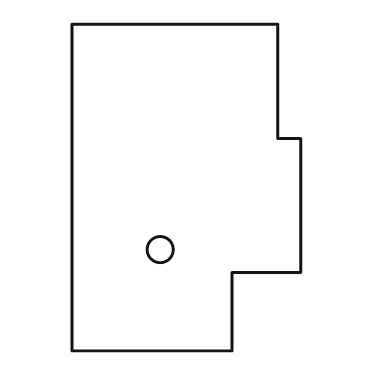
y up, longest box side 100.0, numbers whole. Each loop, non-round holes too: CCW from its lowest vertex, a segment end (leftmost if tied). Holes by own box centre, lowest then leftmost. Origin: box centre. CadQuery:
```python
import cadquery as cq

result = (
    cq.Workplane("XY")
    .moveTo(-35.0, -50.0)
    .lineTo(14.0, -50.0)
    .lineTo(14.0, -26.0)
    .lineTo(35.0, -26.0)
    .lineTo(35.0, 15.0)
    .lineTo(28.0, 15.0)
    .lineTo(28.0, 50.0)
    .lineTo(-35.0, 50.0)
    .close()
    .moveTo(-8.0, -19.0)
    .circle(4.0)
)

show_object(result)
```